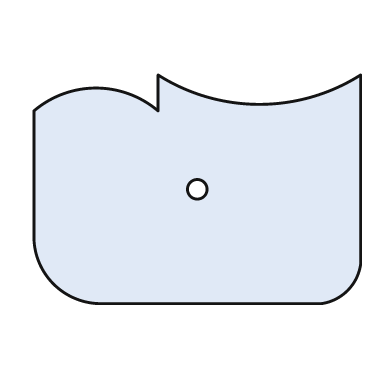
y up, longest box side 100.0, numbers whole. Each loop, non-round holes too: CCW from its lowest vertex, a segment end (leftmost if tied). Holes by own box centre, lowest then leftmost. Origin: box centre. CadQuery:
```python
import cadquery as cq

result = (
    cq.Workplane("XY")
    .moveTo(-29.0, -35.0)
    .lineTo(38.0, -35.0)
    .threePointArc((46.0, -31.0), (50.0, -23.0))
    .lineTo(50.0, 35.0)
    .threePointArc((19.0, 26.0), (-12.0, 35.0))
    .lineTo(-12.0, 24.0)
    .threePointArc((-31.0, 31.0), (-50.0, 24.0))
    .lineTo(-50.0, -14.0)
    .threePointArc((-44.0, -29.0), (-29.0, -35.0))
    .close()
    .moveTo(0.0, 0.0)
    .circle(3.0)
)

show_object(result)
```